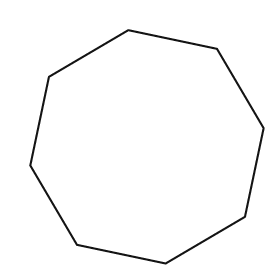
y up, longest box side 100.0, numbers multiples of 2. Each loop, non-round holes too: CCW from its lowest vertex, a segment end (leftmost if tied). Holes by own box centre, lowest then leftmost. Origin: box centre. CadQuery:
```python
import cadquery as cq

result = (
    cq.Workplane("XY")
    .moveTo(8.0, -50.0)
    .lineTo(42.0, -30.0)
    .lineTo(50.0, 8.0)
    .lineTo(30.0, 42.0)
    .lineTo(-8.0, 50.0)
    .lineTo(-42.0, 30.0)
    .lineTo(-50.0, -8.0)
    .lineTo(-30.0, -42.0)
    .close()
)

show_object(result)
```